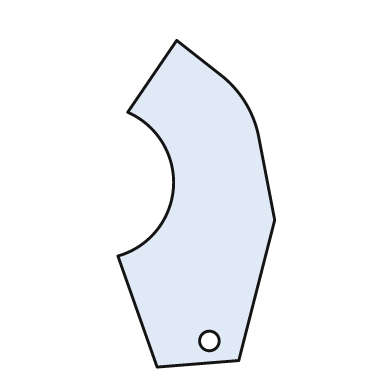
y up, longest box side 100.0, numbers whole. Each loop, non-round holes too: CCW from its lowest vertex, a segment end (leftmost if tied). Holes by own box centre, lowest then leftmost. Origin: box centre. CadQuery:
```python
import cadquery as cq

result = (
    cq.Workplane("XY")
    .moveTo(-12.0, -50.0)
    .lineTo(13.0, -48.0)
    .lineTo(24.0, -5.0)
    .lineTo(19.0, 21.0)
    .threePointArc((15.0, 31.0), (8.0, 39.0))
    .lineTo(-6.0, 50.0)
    .lineTo(-21.0, 28.0)
    .threePointArc((-7.0, 5.0), (-24.0, -16.0))
    .close()
    .moveTo(4.0, -42.0)
    .circle(3.0)
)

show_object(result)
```